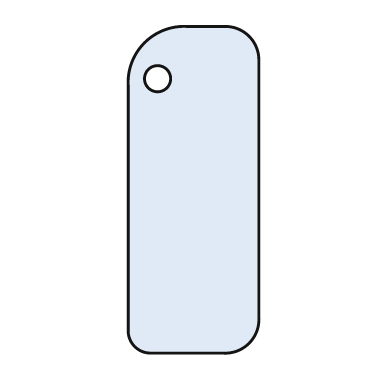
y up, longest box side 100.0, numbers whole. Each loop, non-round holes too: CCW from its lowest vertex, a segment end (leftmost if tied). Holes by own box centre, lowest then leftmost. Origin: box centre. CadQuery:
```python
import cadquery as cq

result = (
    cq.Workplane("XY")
    .moveTo(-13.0, -50.0)
    .lineTo(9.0, -50.0)
    .threePointArc((17.0, -47.0), (20.0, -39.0))
    .lineTo(20.0, 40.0)
    .threePointArc((17.0, 47.0), (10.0, 50.0))
    .lineTo(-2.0, 50.0)
    .threePointArc((-15.0, 45.0), (-20.0, 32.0))
    .lineTo(-20.0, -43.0)
    .threePointArc((-18.0, -48.0), (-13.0, -50.0))
    .close()
    .moveTo(-11.0, 34.0)
    .circle(4.0)
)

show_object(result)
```